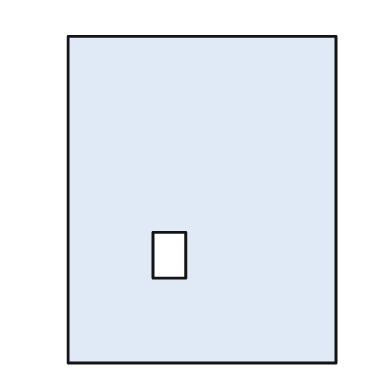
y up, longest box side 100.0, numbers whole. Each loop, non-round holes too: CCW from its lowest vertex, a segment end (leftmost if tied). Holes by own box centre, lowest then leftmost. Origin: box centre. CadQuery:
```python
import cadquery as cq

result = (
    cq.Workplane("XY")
    .moveTo(-41.0, -50.0)
    .lineTo(41.0, -50.0)
    .lineTo(41.0, 50.0)
    .lineTo(-41.0, 50.0)
    .close()
    .moveTo(-15.0, -24.0)
    .lineTo(-5.0, -24.0)
    .lineTo(-5.0, -10.0)
    .lineTo(-15.0, -10.0)
    .close()
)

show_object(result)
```